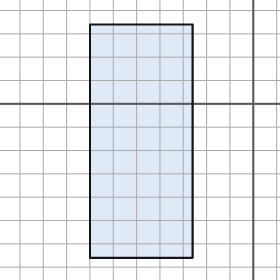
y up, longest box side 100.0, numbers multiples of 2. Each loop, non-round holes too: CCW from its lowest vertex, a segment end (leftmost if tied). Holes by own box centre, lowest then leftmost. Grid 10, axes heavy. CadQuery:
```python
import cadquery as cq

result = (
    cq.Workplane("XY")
    .moveTo(-70.0, -66.0)
    .lineTo(-26.0, -66.0)
    .lineTo(-26.0, 34.0)
    .lineTo(-70.0, 34.0)
    .close()
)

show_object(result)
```